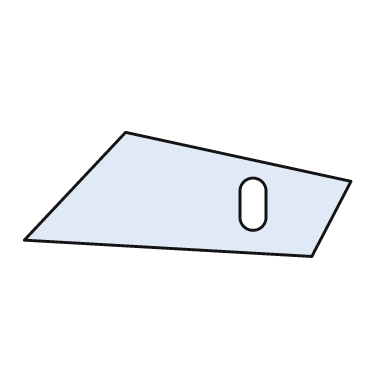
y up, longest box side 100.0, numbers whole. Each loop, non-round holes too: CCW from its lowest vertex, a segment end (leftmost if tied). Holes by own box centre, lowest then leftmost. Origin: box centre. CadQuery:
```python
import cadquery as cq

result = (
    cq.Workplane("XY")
    .moveTo(38.0, -19.0)
    .lineTo(50.0, 4.0)
    .lineTo(-19.0, 19.0)
    .lineTo(-50.0, -14.0)
    .close()
    .moveTo(16.0, -7.0)
    .threePointArc((20.0, -11.0), (24.0, -7.0))
    .lineTo(24.0, 1.0)
    .threePointArc((20.0, 5.0), (16.0, 1.0))
    .close()
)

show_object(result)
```